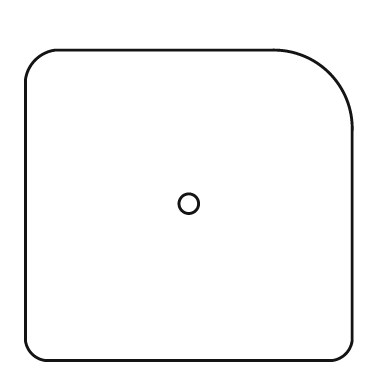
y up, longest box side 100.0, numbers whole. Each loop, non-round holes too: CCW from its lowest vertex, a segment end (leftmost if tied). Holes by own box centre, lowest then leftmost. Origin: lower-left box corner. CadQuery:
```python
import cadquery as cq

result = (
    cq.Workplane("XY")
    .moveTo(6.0, 0.0)
    .lineTo(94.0, 0.0)
    .threePointArc((98.0, 2.0), (100.0, 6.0))
    .lineTo(100.0, 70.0)
    .threePointArc((93.0, 88.0), (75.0, 95.0))
    .lineTo(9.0, 95.0)
    .threePointArc((3.0, 92.0), (0.0, 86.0))
    .lineTo(0.0, 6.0)
    .threePointArc((2.0, 2.0), (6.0, 0.0))
    .close()
    .moveTo(50.0, 48.0)
    .circle(3.0)
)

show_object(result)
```